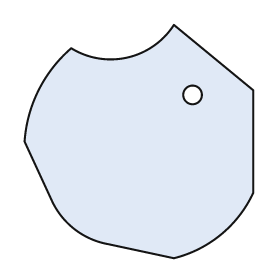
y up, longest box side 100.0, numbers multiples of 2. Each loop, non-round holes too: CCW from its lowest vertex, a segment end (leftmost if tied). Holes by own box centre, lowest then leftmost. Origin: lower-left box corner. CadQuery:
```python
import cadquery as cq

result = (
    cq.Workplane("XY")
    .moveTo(64.0, 0.0)
    .threePointArc((84.0, 10.0), (98.0, 28.0))
    .lineTo(98.0, 72.0)
    .lineTo(64.0, 100.0)
    .threePointArc((44.0, 86.0), (20.0, 90.0))
    .threePointArc((6.0, 72.0), (0.0, 50.0))
    .lineTo(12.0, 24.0)
    .threePointArc((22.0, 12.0), (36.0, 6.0))
    .close()
    .moveTo(72.0, 70.0)
    .circle(4.0)
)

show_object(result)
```